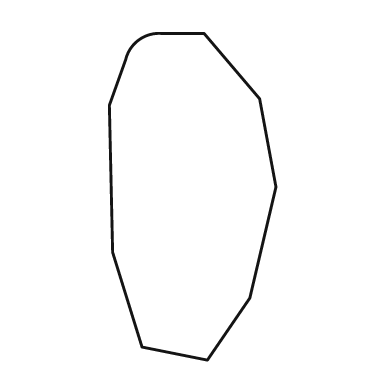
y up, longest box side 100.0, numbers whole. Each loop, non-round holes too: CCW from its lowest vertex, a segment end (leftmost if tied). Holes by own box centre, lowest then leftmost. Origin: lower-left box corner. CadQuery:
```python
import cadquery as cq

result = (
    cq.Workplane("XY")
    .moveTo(30.0, 0.0)
    .lineTo(43.0, 19.0)
    .lineTo(51.0, 53.0)
    .lineTo(46.0, 80.0)
    .lineTo(29.0, 100.0)
    .lineTo(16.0, 100.0)
    .threePointArc((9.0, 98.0), (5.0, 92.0))
    .lineTo(0.0, 78.0)
    .lineTo(1.0, 33.0)
    .lineTo(10.0, 4.0)
    .close()
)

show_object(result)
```